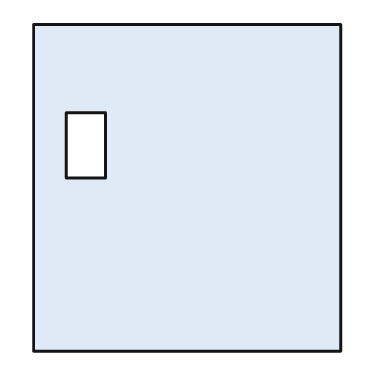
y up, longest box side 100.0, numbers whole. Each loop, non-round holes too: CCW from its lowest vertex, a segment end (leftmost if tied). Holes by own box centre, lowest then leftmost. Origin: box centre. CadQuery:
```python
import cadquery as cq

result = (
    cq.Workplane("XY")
    .moveTo(-47.0, -50.0)
    .lineTo(47.0, -50.0)
    .lineTo(47.0, 50.0)
    .lineTo(-47.0, 50.0)
    .close()
    .moveTo(-37.0, 3.0)
    .lineTo(-25.0, 3.0)
    .lineTo(-25.0, 23.0)
    .lineTo(-37.0, 23.0)
    .close()
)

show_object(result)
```